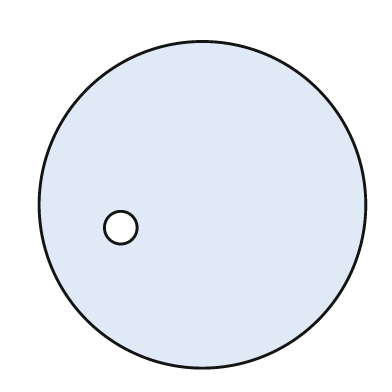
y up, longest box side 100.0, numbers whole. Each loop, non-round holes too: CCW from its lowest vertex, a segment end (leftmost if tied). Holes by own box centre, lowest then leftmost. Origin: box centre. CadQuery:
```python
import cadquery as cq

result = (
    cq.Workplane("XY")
    .moveTo(0.0, 0.0)
    .circle(50.0)
    .moveTo(-25.0, -7.0)
    .circle(5.0)
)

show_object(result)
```